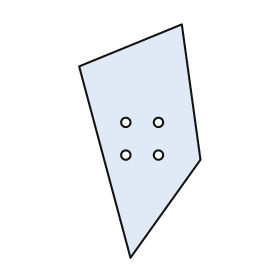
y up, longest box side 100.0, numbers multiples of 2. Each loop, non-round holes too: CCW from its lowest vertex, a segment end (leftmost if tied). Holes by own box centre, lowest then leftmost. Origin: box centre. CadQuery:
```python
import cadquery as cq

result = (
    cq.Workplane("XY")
    .moveTo(-4.0, -50.0)
    .lineTo(26.0, -8.0)
    .lineTo(18.0, 50.0)
    .lineTo(-26.0, 32.0)
    .close()
    .moveTo(-6.0, -6.0)
    .circle(2.0)
    .moveTo(8.0, -6.0)
    .circle(2.0)
    .moveTo(-6.0, 8.0)
    .circle(2.0)
    .moveTo(8.0, 8.0)
    .circle(2.0)
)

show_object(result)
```